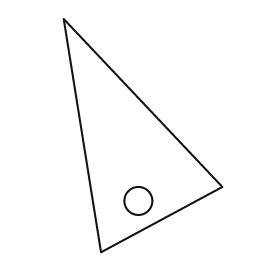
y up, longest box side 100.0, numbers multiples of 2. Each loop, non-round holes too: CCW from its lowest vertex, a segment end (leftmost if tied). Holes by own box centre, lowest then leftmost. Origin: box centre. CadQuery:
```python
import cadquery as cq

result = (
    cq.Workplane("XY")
    .moveTo(-18.0, -50.0)
    .lineTo(34.0, -22.0)
    .lineTo(-34.0, 50.0)
    .close()
    .moveTo(-2.0, -28.0)
    .circle(6.0)
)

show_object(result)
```